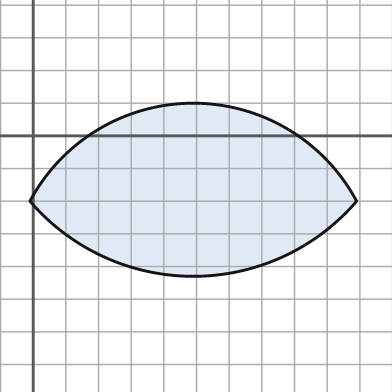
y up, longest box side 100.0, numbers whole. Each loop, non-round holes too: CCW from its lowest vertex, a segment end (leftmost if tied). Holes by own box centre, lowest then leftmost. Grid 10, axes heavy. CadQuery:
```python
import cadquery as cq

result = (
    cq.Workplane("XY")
    .moveTo(-1.0, -20.0)
    .threePointArc((49.0, -43.0), (99.0, -20.0))
    .threePointArc((49.0, 10.0), (-1.0, -20.0))
    .close()
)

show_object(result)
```